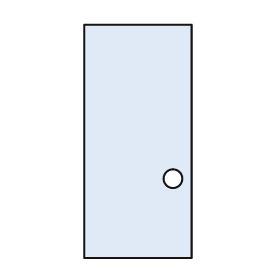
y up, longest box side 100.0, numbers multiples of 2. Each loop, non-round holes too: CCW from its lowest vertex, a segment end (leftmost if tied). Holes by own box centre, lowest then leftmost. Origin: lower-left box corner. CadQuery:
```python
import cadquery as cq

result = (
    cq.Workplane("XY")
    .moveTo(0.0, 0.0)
    .lineTo(46.0, 0.0)
    .lineTo(46.0, 100.0)
    .lineTo(0.0, 100.0)
    .close()
    .moveTo(38.0, 34.0)
    .circle(4.0)
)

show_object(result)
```